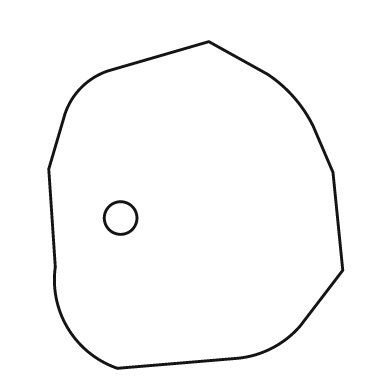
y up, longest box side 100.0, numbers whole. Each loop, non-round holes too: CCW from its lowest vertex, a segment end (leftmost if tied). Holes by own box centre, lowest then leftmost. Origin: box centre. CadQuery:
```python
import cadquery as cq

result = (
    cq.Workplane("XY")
    .moveTo(-24.0, -50.0)
    .lineTo(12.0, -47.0)
    .threePointArc((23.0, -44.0), (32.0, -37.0))
    .lineTo(45.0, -20.0)
    .lineTo(42.0, 10.0)
    .lineTo(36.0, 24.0)
    .threePointArc((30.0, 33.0), (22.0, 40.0))
    .lineTo(4.0, 50.0)
    .lineTo(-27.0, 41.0)
    .threePointArc((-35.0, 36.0), (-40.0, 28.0))
    .lineTo(-45.0, 11.0)
    .lineTo(-43.0, -19.0)
    .threePointArc((-39.0, -38.0), (-24.0, -50.0))
    .close()
    .moveTo(-23.0, -4.0)
    .circle(5.0)
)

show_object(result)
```